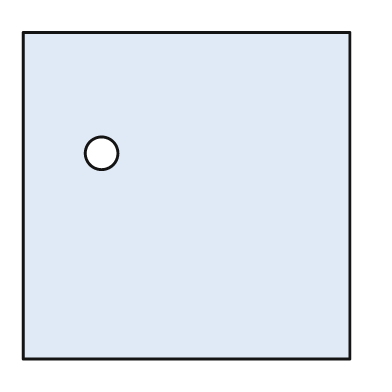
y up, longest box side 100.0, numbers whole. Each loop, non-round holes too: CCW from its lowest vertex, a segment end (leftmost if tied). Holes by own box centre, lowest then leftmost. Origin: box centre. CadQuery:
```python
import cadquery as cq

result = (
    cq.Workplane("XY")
    .moveTo(-50.0, -50.0)
    .lineTo(50.0, -50.0)
    .lineTo(50.0, 50.0)
    .lineTo(-50.0, 50.0)
    .close()
    .moveTo(-26.0, 13.0)
    .circle(5.0)
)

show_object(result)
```